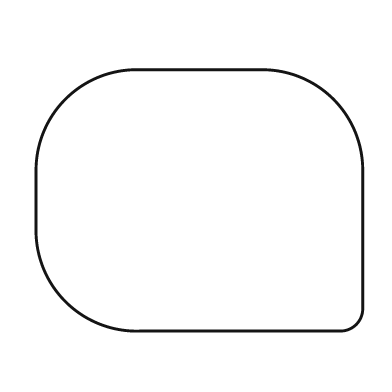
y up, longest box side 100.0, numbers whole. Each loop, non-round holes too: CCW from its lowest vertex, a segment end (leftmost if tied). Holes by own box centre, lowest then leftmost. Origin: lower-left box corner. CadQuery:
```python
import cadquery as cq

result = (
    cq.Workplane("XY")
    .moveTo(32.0, 0.0)
    .lineTo(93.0, 0.0)
    .threePointArc((98.0, 2.0), (100.0, 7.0))
    .lineTo(100.0, 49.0)
    .threePointArc((91.0, 71.0), (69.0, 80.0))
    .lineTo(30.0, 80.0)
    .threePointArc((9.0, 71.0), (0.0, 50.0))
    .lineTo(0.0, 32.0)
    .threePointArc((9.0, 9.0), (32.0, 0.0))
    .close()
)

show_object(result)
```